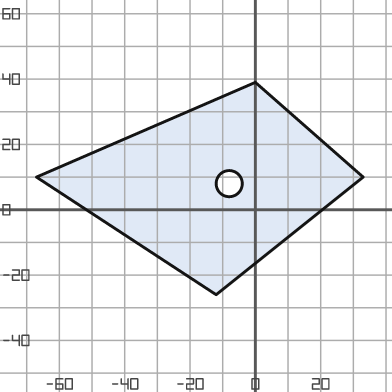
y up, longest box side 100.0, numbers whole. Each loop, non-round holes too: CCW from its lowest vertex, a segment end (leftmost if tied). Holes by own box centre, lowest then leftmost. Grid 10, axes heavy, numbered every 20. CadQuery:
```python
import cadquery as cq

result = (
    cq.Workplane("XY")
    .moveTo(-12.0, -26.0)
    .lineTo(33.0, 10.0)
    .lineTo(0.0, 39.0)
    .lineTo(-67.0, 10.0)
    .close()
    .moveTo(-8.0, 8.0)
    .circle(4.0)
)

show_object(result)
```